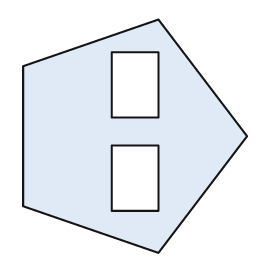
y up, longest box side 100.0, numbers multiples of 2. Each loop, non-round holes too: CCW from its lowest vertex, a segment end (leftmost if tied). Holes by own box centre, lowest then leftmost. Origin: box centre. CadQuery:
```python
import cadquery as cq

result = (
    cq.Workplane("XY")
    .moveTo(10.0, -50.0)
    .lineTo(48.0, 0.0)
    .lineTo(10.0, 50.0)
    .lineTo(-48.0, 30.0)
    .lineTo(-48.0, -30.0)
    .close()
    .moveTo(-10.0, -32.0)
    .lineTo(10.0, -32.0)
    .lineTo(10.0, -4.0)
    .lineTo(-10.0, -4.0)
    .close()
    .moveTo(-10.0, 8.0)
    .lineTo(10.0, 8.0)
    .lineTo(10.0, 36.0)
    .lineTo(-10.0, 36.0)
    .close()
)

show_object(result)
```